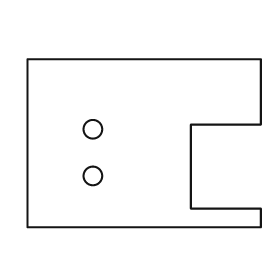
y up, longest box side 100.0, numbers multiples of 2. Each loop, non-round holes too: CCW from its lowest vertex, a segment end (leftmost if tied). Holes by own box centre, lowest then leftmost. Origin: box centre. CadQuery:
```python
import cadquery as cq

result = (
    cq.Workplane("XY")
    .moveTo(-50.0, -36.0)
    .lineTo(50.0, -36.0)
    .lineTo(50.0, -28.0)
    .lineTo(20.0, -28.0)
    .lineTo(20.0, 8.0)
    .lineTo(50.0, 8.0)
    .lineTo(50.0, 36.0)
    .lineTo(-50.0, 36.0)
    .close()
    .moveTo(-22.0, -14.0)
    .circle(4.0)
    .moveTo(-22.0, 6.0)
    .circle(4.0)
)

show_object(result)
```